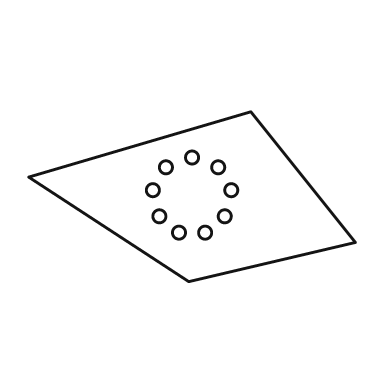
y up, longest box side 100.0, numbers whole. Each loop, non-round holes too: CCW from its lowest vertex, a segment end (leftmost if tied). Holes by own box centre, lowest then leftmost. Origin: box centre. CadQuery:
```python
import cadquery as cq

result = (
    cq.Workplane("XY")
    .moveTo(-1.0, -26.0)
    .lineTo(50.0, -14.0)
    .lineTo(18.0, 26.0)
    .lineTo(-50.0, 6.0)
    .close()
    .moveTo(-4.0, -11.0)
    .circle(2.0)
    .moveTo(4.0, -11.0)
    .circle(2.0)
    .moveTo(-10.0, -6.0)
    .circle(2.0)
    .moveTo(10.0, -6.0)
    .circle(2.0)
    .moveTo(-12.0, 2.0)
    .circle(2.0)
    .moveTo(12.0, 2.0)
    .circle(2.0)
    .moveTo(-8.0, 9.0)
    .circle(2.0)
    .moveTo(8.0, 9.0)
    .circle(2.0)
    .moveTo(0.0, 12.0)
    .circle(2.0)
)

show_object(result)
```